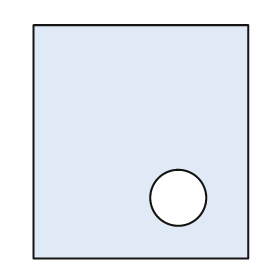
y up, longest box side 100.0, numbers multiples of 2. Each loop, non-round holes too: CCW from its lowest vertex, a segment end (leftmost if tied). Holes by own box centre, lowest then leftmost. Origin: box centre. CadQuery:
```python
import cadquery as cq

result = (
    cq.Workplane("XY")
    .moveTo(-46.0, -50.0)
    .lineTo(46.0, -50.0)
    .lineTo(46.0, 50.0)
    .lineTo(-46.0, 50.0)
    .close()
    .moveTo(16.0, -24.0)
    .circle(12.0)
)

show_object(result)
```